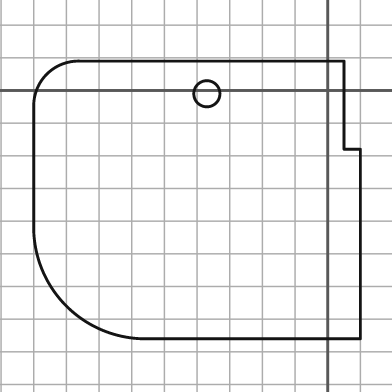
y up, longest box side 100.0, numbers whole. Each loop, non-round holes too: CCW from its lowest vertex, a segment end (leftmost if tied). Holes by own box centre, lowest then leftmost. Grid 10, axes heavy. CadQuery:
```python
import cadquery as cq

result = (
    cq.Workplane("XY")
    .moveTo(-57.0, -76.0)
    .lineTo(10.0, -76.0)
    .lineTo(10.0, -18.0)
    .lineTo(5.0, -18.0)
    .lineTo(5.0, 9.0)
    .lineTo(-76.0, 9.0)
    .threePointArc((-86.0, 5.0), (-90.0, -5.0))
    .lineTo(-90.0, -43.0)
    .threePointArc((-80.0, -66.0), (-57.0, -76.0))
    .close()
    .moveTo(-37.0, -1.0)
    .circle(4.0)
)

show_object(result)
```